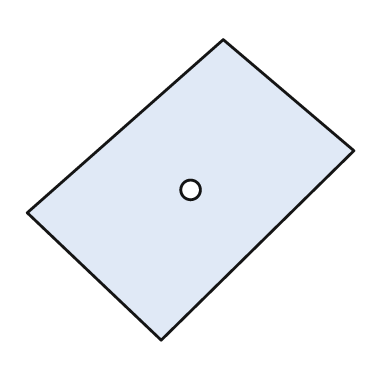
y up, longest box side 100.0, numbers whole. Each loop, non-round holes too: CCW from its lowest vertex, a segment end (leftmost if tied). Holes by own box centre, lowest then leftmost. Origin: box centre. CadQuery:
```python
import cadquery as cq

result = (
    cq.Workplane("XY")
    .moveTo(-9.0, -46.0)
    .lineTo(50.0, 12.0)
    .lineTo(10.0, 46.0)
    .lineTo(-50.0, -7.0)
    .close()
    .moveTo(0.0, 0.0)
    .circle(3.0)
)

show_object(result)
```